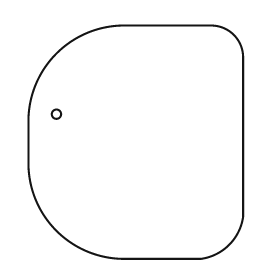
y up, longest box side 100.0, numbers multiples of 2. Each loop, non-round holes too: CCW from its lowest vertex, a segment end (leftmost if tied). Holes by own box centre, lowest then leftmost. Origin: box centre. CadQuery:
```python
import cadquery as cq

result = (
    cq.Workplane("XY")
    .moveTo(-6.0, -50.0)
    .lineTo(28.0, -50.0)
    .threePointArc((40.0, -44.0), (46.0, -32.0))
    .lineTo(46.0, 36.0)
    .threePointArc((42.0, 46.0), (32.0, 50.0))
    .lineTo(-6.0, 50.0)
    .threePointArc((-34.0, 38.0), (-46.0, 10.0))
    .lineTo(-46.0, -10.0)
    .threePointArc((-34.0, -38.0), (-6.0, -50.0))
    .close()
    .moveTo(-34.0, 12.0)
    .circle(2.0)
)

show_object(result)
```